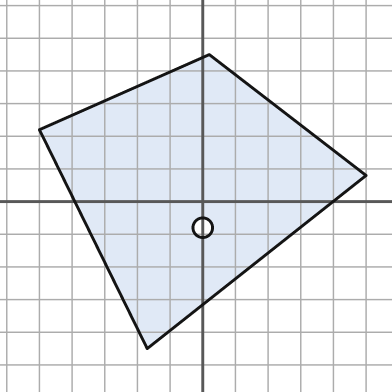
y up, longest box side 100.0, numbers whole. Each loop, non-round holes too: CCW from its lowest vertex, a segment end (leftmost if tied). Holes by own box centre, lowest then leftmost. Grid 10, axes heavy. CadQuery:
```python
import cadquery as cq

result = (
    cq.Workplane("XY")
    .moveTo(-17.0, -45.0)
    .lineTo(50.0, 8.0)
    .lineTo(2.0, 45.0)
    .lineTo(-50.0, 22.0)
    .close()
    .moveTo(0.0, -8.0)
    .circle(3.0)
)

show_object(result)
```